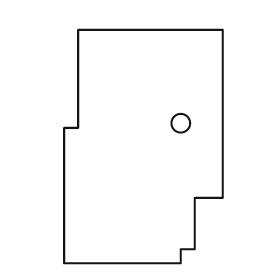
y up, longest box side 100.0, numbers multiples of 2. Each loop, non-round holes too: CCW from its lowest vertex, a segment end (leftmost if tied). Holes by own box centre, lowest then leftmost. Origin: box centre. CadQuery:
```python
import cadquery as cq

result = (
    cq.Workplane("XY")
    .moveTo(-34.0, -50.0)
    .lineTo(16.0, -50.0)
    .lineTo(16.0, -44.0)
    .lineTo(22.0, -44.0)
    .lineTo(22.0, -22.0)
    .lineTo(34.0, -22.0)
    .lineTo(34.0, 50.0)
    .lineTo(-28.0, 50.0)
    .lineTo(-28.0, 8.0)
    .lineTo(-34.0, 8.0)
    .close()
    .moveTo(16.0, 10.0)
    .circle(4.0)
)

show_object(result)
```